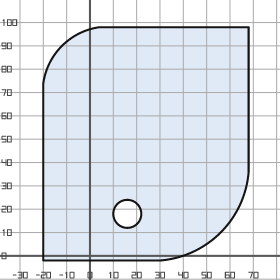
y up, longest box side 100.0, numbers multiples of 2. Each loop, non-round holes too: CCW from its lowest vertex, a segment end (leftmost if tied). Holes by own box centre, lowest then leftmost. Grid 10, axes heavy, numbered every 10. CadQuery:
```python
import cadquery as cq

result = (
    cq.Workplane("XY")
    .moveTo(-20.0, -2.0)
    .lineTo(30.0, -2.0)
    .threePointArc((56.0, 10.0), (68.0, 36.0))
    .lineTo(68.0, 98.0)
    .lineTo(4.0, 98.0)
    .threePointArc((-12.0, 90.0), (-20.0, 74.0))
    .close()
    .moveTo(16.0, 18.0)
    .circle(6.0)
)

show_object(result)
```